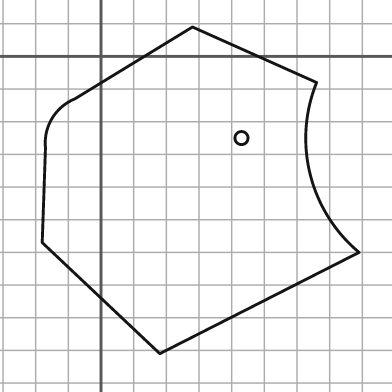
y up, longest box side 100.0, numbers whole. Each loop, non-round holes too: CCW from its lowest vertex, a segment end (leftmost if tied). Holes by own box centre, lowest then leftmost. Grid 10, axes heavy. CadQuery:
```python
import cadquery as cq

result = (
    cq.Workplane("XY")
    .moveTo(18.0, -91.0)
    .lineTo(79.0, -60.0)
    .threePointArc((64.0, -36.0), (66.0, -8.0))
    .lineTo(28.0, 9.0)
    .lineTo(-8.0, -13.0)
    .threePointArc((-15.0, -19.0), (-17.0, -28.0))
    .lineTo(-18.0, -57.0)
    .close()
    .moveTo(43.0, -25.0)
    .circle(2.0)
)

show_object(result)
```